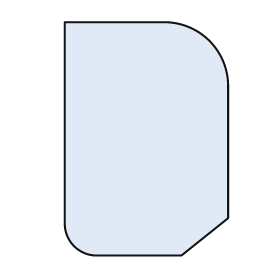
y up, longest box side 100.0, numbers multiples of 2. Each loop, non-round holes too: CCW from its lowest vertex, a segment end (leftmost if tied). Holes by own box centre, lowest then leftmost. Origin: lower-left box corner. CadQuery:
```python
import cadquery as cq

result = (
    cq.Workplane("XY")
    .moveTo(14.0, 0.0)
    .lineTo(50.0, 0.0)
    .lineTo(70.0, 16.0)
    .lineTo(70.0, 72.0)
    .threePointArc((62.0, 92.0), (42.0, 100.0))
    .lineTo(0.0, 100.0)
    .lineTo(0.0, 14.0)
    .threePointArc((4.0, 4.0), (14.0, 0.0))
    .close()
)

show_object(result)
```